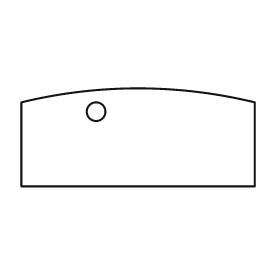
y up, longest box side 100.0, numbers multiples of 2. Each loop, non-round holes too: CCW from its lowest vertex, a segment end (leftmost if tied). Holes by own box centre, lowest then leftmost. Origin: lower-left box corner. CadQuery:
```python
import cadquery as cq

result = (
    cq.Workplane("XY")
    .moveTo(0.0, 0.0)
    .lineTo(100.0, 0.0)
    .lineTo(100.0, 36.0)
    .threePointArc((50.0, 42.0), (0.0, 36.0))
    .close()
    .moveTo(32.0, 32.0)
    .circle(4.0)
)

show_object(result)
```